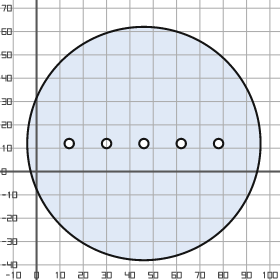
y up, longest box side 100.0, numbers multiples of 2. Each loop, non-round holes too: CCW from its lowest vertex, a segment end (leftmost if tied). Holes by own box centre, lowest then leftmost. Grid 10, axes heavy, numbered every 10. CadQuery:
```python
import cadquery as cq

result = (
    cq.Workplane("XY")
    .moveTo(46.0, 12.0)
    .circle(50.0)
    .moveTo(14.0, 12.0)
    .circle(2.0)
    .moveTo(30.0, 12.0)
    .circle(2.0)
    .moveTo(46.0, 12.0)
    .circle(2.0)
    .moveTo(62.0, 12.0)
    .circle(2.0)
    .moveTo(78.0, 12.0)
    .circle(2.0)
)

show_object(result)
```